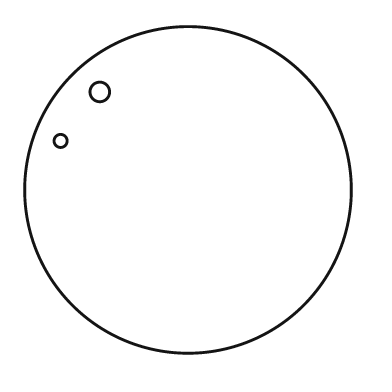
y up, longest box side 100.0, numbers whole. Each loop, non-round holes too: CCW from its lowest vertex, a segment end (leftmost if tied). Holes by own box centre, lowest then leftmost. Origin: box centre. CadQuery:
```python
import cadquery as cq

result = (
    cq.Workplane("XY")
    .moveTo(0.0, 0.0)
    .circle(50.0)
    .moveTo(-39.0, 15.0)
    .circle(2.0)
    .moveTo(-27.0, 30.0)
    .circle(3.0)
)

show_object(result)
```